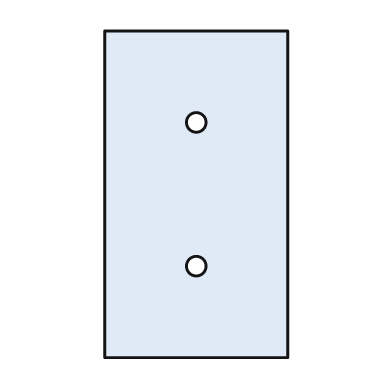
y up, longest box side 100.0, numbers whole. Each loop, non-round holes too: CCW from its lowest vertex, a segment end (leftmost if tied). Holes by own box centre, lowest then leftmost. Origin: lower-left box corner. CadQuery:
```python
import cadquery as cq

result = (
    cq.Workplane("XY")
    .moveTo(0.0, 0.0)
    .lineTo(56.0, 0.0)
    .lineTo(56.0, 100.0)
    .lineTo(0.0, 100.0)
    .close()
    .moveTo(28.0, 28.0)
    .circle(3.0)
    .moveTo(28.0, 72.0)
    .circle(3.0)
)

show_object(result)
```